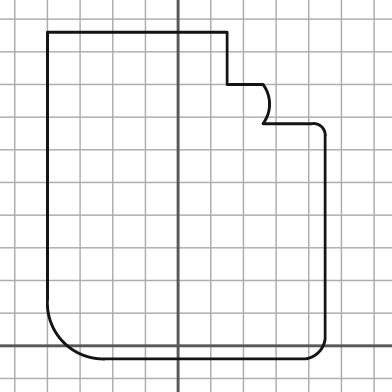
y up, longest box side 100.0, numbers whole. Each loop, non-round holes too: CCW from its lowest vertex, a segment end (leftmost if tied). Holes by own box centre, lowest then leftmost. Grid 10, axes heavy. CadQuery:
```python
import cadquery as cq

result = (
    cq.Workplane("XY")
    .moveTo(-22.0, -4.0)
    .lineTo(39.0, -4.0)
    .threePointArc((43.0, -2.0), (45.0, 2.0))
    .lineTo(45.0, 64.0)
    .threePointArc((44.0, 67.0), (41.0, 68.0))
    .lineTo(26.0, 68.0)
    .threePointArc((28.0, 74.0), (26.0, 80.0))
    .lineTo(15.0, 80.0)
    .lineTo(15.0, 96.0)
    .lineTo(-40.0, 96.0)
    .lineTo(-40.0, 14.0)
    .threePointArc((-35.0, 1.0), (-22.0, -4.0))
    .close()
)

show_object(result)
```